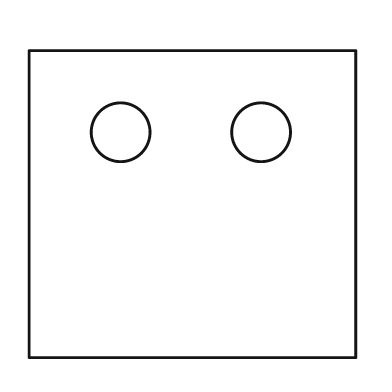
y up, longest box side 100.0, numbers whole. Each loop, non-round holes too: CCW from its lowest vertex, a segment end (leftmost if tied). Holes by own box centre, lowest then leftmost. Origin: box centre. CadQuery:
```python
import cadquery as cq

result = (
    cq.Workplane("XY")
    .moveTo(-50.0, -47.0)
    .lineTo(50.0, -47.0)
    .lineTo(50.0, 47.0)
    .lineTo(-50.0, 47.0)
    .close()
    .moveTo(-22.0, 22.0)
    .circle(9.0)
    .moveTo(21.0, 22.0)
    .circle(9.0)
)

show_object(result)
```